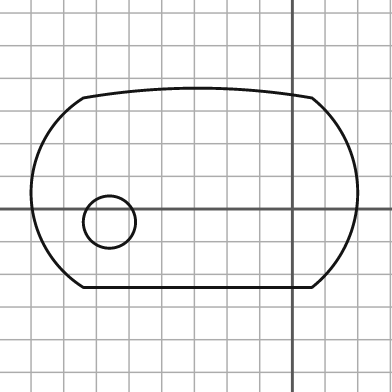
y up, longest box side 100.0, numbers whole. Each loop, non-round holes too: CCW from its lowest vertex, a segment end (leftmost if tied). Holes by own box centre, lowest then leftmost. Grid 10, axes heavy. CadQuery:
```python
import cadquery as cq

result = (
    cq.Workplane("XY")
    .moveTo(-64.0, -24.0)
    .lineTo(6.0, -24.0)
    .threePointArc((20.0, 5.0), (6.0, 34.0))
    .threePointArc((-29.0, 37.0), (-64.0, 34.0))
    .threePointArc((-80.0, 5.0), (-64.0, -24.0))
    .close()
    .moveTo(-56.0, -4.0)
    .circle(8.0)
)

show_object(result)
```